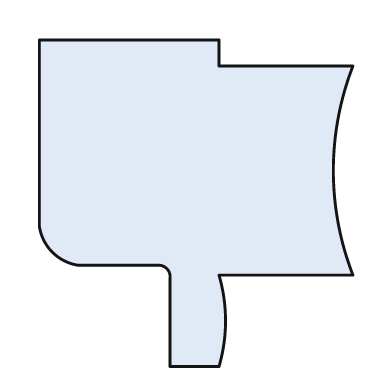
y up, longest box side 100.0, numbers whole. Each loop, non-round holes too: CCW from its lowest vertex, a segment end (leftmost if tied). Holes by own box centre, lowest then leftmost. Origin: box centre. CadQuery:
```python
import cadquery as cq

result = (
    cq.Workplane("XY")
    .moveTo(-8.0, -50.0)
    .lineTo(7.0, -50.0)
    .threePointArc((9.0, -36.0), (7.0, -22.0))
    .lineTo(48.0, -22.0)
    .threePointArc((42.0, 10.0), (48.0, 42.0))
    .lineTo(7.0, 42.0)
    .lineTo(7.0, 50.0)
    .lineTo(-48.0, 50.0)
    .lineTo(-48.0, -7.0)
    .threePointArc((-44.0, -15.0), (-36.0, -19.0))
    .lineTo(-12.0, -19.0)
    .threePointArc((-9.0, -20.0), (-8.0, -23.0))
    .close()
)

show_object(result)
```